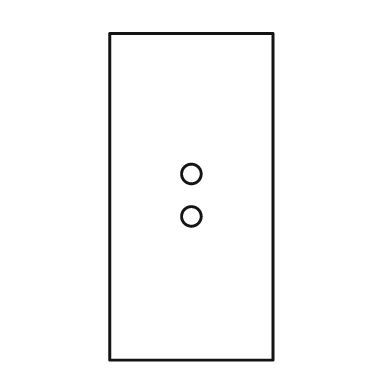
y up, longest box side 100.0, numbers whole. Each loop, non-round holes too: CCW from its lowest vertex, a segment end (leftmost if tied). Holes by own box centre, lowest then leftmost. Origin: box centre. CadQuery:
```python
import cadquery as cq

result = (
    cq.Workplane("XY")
    .moveTo(-25.0, -50.0)
    .lineTo(25.0, -50.0)
    .lineTo(25.0, 50.0)
    .lineTo(-25.0, 50.0)
    .close()
    .moveTo(0.0, -6.0)
    .circle(3.0)
    .moveTo(0.0, 7.0)
    .circle(3.0)
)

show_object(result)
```